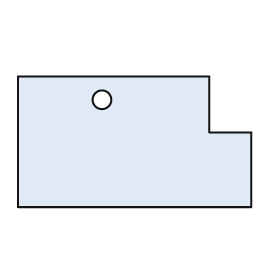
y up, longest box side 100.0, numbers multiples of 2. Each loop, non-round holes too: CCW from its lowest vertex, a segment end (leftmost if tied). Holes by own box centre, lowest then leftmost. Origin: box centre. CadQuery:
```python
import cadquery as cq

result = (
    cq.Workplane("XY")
    .moveTo(-50.0, -28.0)
    .lineTo(50.0, -28.0)
    .lineTo(50.0, 4.0)
    .lineTo(32.0, 4.0)
    .lineTo(32.0, 28.0)
    .lineTo(-50.0, 28.0)
    .close()
    .moveTo(-14.0, 18.0)
    .circle(4.0)
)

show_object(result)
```